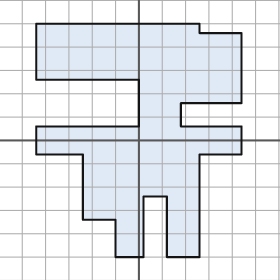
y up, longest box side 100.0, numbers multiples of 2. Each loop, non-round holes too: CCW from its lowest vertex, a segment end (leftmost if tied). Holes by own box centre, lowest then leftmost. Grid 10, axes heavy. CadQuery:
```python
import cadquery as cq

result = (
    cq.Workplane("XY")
    .moveTo(-10.0, -50.0)
    .lineTo(2.0, -50.0)
    .lineTo(2.0, -24.0)
    .lineTo(12.0, -24.0)
    .lineTo(12.0, -50.0)
    .lineTo(26.0, -50.0)
    .lineTo(26.0, -6.0)
    .lineTo(44.0, -6.0)
    .lineTo(44.0, 6.0)
    .lineTo(18.0, 6.0)
    .lineTo(18.0, 16.0)
    .lineTo(44.0, 16.0)
    .lineTo(44.0, 46.0)
    .lineTo(26.0, 46.0)
    .lineTo(26.0, 50.0)
    .lineTo(-44.0, 50.0)
    .lineTo(-44.0, 26.0)
    .lineTo(0.0, 26.0)
    .lineTo(0.0, 6.0)
    .lineTo(-44.0, 6.0)
    .lineTo(-44.0, -6.0)
    .lineTo(-24.0, -6.0)
    .lineTo(-24.0, -34.0)
    .lineTo(-10.0, -34.0)
    .close()
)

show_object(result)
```